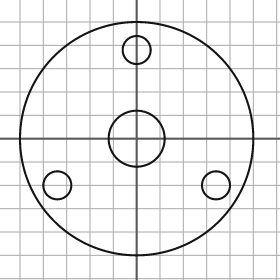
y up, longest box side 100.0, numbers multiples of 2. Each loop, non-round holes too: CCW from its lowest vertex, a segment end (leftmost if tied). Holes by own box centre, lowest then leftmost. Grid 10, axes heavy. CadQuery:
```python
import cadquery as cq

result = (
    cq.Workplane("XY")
    .moveTo(0.0, 0.0)
    .circle(50.0)
    .moveTo(-34.0, -20.0)
    .circle(6.0)
    .moveTo(34.0, -20.0)
    .circle(6.0)
    .moveTo(0.0, 0.0)
    .circle(12.0)
    .moveTo(0.0, 38.0)
    .circle(6.0)
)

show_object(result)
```